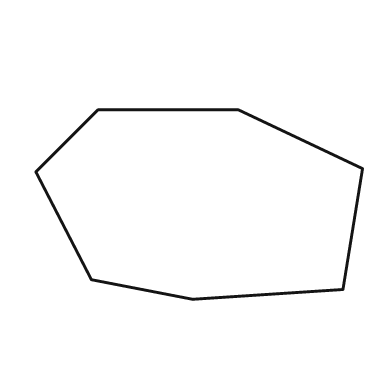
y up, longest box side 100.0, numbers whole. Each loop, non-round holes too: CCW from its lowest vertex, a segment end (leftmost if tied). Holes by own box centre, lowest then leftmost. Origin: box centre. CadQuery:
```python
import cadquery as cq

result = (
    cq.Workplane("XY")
    .moveTo(-2.0, -29.0)
    .lineTo(44.0, -26.0)
    .lineTo(50.0, 11.0)
    .lineTo(12.0, 29.0)
    .lineTo(-31.0, 29.0)
    .lineTo(-50.0, 10.0)
    .lineTo(-33.0, -23.0)
    .close()
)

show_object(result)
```